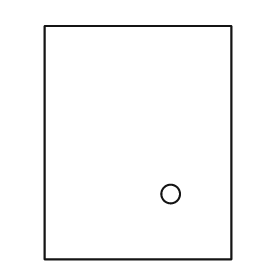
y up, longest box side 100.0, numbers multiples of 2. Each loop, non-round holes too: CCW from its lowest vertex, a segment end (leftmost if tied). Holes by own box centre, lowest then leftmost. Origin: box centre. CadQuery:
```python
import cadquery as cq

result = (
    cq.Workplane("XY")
    .moveTo(-40.0, -50.0)
    .lineTo(40.0, -50.0)
    .lineTo(40.0, 50.0)
    .lineTo(-40.0, 50.0)
    .close()
    .moveTo(14.0, -22.0)
    .circle(4.0)
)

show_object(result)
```